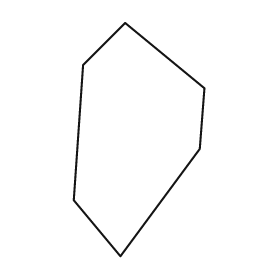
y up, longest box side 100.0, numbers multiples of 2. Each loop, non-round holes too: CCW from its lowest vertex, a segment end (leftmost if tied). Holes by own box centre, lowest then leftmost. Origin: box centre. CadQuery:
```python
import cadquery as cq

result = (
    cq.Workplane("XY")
    .moveTo(-8.0, -50.0)
    .lineTo(26.0, -4.0)
    .lineTo(28.0, 22.0)
    .lineTo(-6.0, 50.0)
    .lineTo(-24.0, 32.0)
    .lineTo(-28.0, -26.0)
    .close()
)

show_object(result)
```